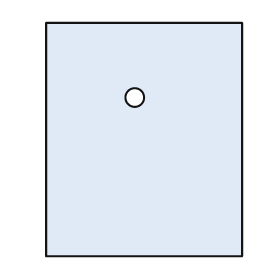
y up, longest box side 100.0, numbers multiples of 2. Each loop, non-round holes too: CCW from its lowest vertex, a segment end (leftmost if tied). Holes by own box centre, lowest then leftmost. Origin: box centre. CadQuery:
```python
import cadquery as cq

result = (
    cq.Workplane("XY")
    .moveTo(-42.0, -50.0)
    .lineTo(42.0, -50.0)
    .lineTo(42.0, 50.0)
    .lineTo(-42.0, 50.0)
    .close()
    .moveTo(-4.0, 18.0)
    .circle(4.0)
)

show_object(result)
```